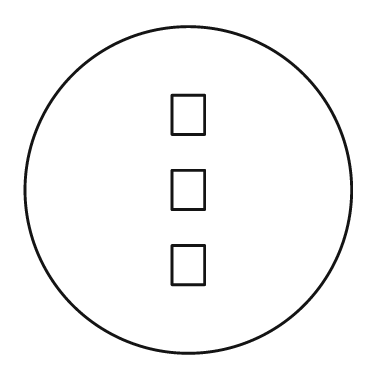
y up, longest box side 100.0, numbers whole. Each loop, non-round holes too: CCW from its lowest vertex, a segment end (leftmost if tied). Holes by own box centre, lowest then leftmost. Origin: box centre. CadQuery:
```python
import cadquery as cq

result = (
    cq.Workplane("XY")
    .moveTo(0.0, 0.0)
    .circle(50.0)
    .moveTo(-5.0, -29.0)
    .lineTo(5.0, -29.0)
    .lineTo(5.0, -17.0)
    .lineTo(-5.0, -17.0)
    .close()
    .moveTo(-5.0, -6.0)
    .lineTo(5.0, -6.0)
    .lineTo(5.0, 6.0)
    .lineTo(-5.0, 6.0)
    .close()
    .moveTo(-5.0, 17.0)
    .lineTo(5.0, 17.0)
    .lineTo(5.0, 29.0)
    .lineTo(-5.0, 29.0)
    .close()
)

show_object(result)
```